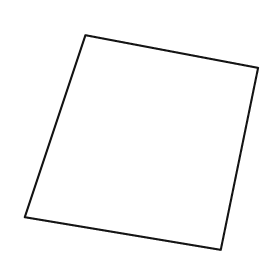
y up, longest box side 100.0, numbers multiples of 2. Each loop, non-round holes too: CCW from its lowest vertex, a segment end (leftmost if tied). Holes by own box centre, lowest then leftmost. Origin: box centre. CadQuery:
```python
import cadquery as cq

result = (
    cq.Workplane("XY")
    .moveTo(34.0, -46.0)
    .lineTo(50.0, 32.0)
    .lineTo(-24.0, 46.0)
    .lineTo(-50.0, -32.0)
    .close()
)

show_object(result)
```